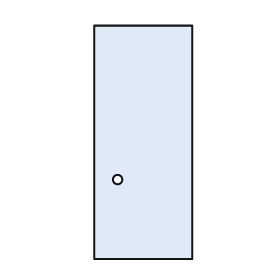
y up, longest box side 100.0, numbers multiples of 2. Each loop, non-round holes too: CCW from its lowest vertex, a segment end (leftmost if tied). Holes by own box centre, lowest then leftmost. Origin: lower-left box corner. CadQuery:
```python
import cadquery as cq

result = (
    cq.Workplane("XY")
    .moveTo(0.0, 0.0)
    .lineTo(42.0, 0.0)
    .lineTo(42.0, 100.0)
    .lineTo(0.0, 100.0)
    .close()
    .moveTo(10.0, 34.0)
    .circle(2.0)
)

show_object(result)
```